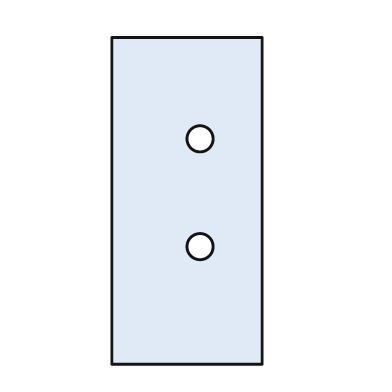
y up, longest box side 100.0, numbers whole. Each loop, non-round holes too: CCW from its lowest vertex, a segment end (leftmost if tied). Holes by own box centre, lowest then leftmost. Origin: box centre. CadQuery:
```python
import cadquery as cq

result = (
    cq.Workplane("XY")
    .moveTo(-23.0, -50.0)
    .lineTo(23.0, -50.0)
    .lineTo(23.0, 50.0)
    .lineTo(-23.0, 50.0)
    .close()
    .moveTo(4.0, -14.0)
    .circle(4.0)
    .moveTo(4.0, 19.0)
    .circle(4.0)
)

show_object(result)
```